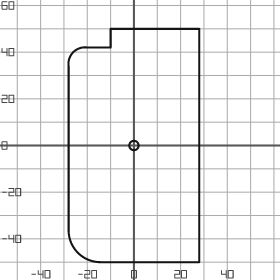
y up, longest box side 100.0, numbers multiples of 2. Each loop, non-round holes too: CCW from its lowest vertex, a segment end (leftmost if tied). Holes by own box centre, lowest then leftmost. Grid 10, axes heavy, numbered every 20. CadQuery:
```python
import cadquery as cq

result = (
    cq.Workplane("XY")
    .moveTo(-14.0, -50.0)
    .lineTo(28.0, -50.0)
    .lineTo(28.0, 50.0)
    .lineTo(-10.0, 50.0)
    .lineTo(-10.0, 42.0)
    .lineTo(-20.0, 42.0)
    .threePointArc((-26.0, 40.0), (-28.0, 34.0))
    .lineTo(-28.0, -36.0)
    .threePointArc((-24.0, -46.0), (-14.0, -50.0))
    .close()
    .moveTo(0.0, 0.0)
    .circle(2.0)
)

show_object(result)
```